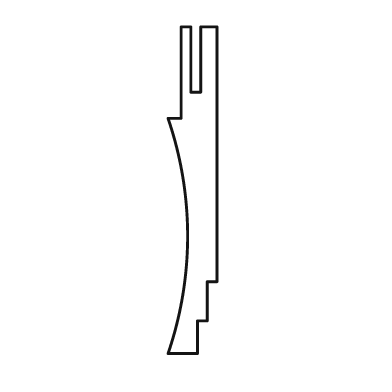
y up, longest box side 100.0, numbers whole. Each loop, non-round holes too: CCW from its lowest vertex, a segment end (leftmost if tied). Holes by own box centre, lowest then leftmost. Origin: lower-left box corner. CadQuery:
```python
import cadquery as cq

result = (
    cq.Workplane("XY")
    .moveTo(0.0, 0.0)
    .lineTo(9.0, 0.0)
    .lineTo(9.0, 10.0)
    .lineTo(12.0, 10.0)
    .lineTo(12.0, 22.0)
    .lineTo(15.0, 22.0)
    .lineTo(15.0, 100.0)
    .lineTo(10.0, 100.0)
    .lineTo(10.0, 80.0)
    .lineTo(7.0, 80.0)
    .lineTo(7.0, 100.0)
    .lineTo(4.0, 100.0)
    .lineTo(4.0, 72.0)
    .lineTo(0.0, 72.0)
    .threePointArc((6.0, 36.0), (0.0, 0.0))
    .close()
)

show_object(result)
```